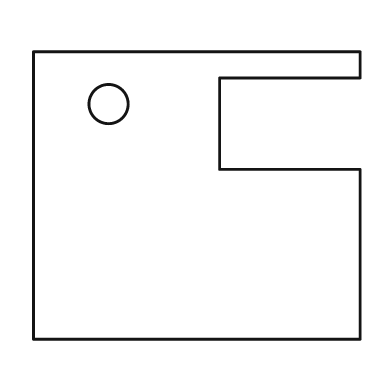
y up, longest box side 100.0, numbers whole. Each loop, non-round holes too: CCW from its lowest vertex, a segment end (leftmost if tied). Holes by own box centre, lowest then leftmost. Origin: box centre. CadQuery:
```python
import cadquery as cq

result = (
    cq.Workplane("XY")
    .moveTo(-50.0, -44.0)
    .lineTo(50.0, -44.0)
    .lineTo(50.0, 8.0)
    .lineTo(7.0, 8.0)
    .lineTo(7.0, 36.0)
    .lineTo(50.0, 36.0)
    .lineTo(50.0, 44.0)
    .lineTo(-50.0, 44.0)
    .close()
    .moveTo(-27.0, 28.0)
    .circle(6.0)
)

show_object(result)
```